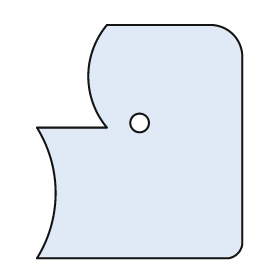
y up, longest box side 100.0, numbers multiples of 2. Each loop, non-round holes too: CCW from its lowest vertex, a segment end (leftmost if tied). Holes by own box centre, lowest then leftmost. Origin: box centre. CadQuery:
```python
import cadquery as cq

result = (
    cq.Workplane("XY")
    .moveTo(-44.0, -50.0)
    .lineTo(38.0, -50.0)
    .threePointArc((42.0, -48.0), (44.0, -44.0))
    .lineTo(44.0, 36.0)
    .threePointArc((40.0, 46.0), (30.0, 50.0))
    .lineTo(-14.0, 50.0)
    .threePointArc((-22.0, 28.0), (-14.0, 6.0))
    .lineTo(-44.0, 6.0)
    .threePointArc((-36.0, -22.0), (-44.0, -50.0))
    .close()
    .moveTo(0.0, 8.0)
    .circle(4.0)
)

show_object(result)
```